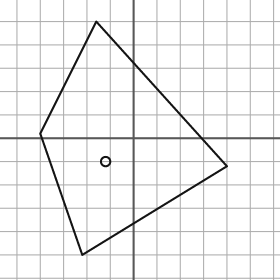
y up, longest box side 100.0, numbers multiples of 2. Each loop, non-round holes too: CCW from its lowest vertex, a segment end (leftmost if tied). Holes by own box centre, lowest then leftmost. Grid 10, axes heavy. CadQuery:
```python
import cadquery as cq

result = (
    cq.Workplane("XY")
    .moveTo(-22.0, -50.0)
    .lineTo(40.0, -12.0)
    .lineTo(-16.0, 50.0)
    .lineTo(-40.0, 2.0)
    .close()
    .moveTo(-12.0, -10.0)
    .circle(2.0)
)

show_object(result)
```